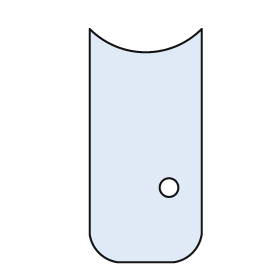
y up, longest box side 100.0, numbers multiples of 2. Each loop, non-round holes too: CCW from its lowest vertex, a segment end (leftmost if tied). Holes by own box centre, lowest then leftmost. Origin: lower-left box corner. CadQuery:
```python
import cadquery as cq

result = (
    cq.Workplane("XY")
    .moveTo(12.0, 0.0)
    .lineTo(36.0, 0.0)
    .threePointArc((44.0, 4.0), (48.0, 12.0))
    .lineTo(48.0, 100.0)
    .threePointArc((24.0, 90.0), (0.0, 100.0))
    .lineTo(0.0, 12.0)
    .threePointArc((4.0, 4.0), (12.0, 0.0))
    .close()
    .moveTo(34.0, 32.0)
    .circle(4.0)
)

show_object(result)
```